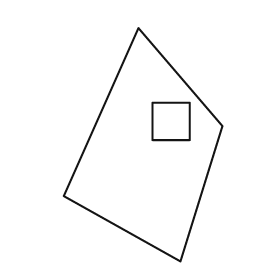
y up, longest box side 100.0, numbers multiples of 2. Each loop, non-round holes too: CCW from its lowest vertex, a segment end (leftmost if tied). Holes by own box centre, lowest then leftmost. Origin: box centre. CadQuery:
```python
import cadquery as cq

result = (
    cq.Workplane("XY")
    .moveTo(16.0, -50.0)
    .lineTo(34.0, 8.0)
    .lineTo(-2.0, 50.0)
    .lineTo(-34.0, -22.0)
    .close()
    .moveTo(4.0, 2.0)
    .lineTo(20.0, 2.0)
    .lineTo(20.0, 18.0)
    .lineTo(4.0, 18.0)
    .close()
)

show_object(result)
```